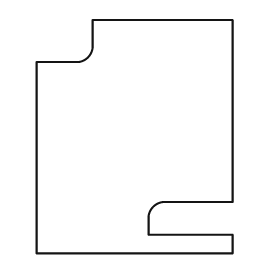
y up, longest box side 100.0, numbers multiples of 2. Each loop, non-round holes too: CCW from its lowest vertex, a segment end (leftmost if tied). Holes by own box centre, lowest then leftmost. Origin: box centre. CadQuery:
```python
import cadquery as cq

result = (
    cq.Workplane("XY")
    .moveTo(-42.0, -50.0)
    .lineTo(42.0, -50.0)
    .lineTo(42.0, -42.0)
    .lineTo(6.0, -42.0)
    .lineTo(6.0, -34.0)
    .threePointArc((8.0, -30.0), (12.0, -28.0))
    .lineTo(42.0, -28.0)
    .lineTo(42.0, 50.0)
    .lineTo(-18.0, 50.0)
    .lineTo(-18.0, 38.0)
    .threePointArc((-20.0, 34.0), (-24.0, 32.0))
    .lineTo(-42.0, 32.0)
    .close()
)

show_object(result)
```